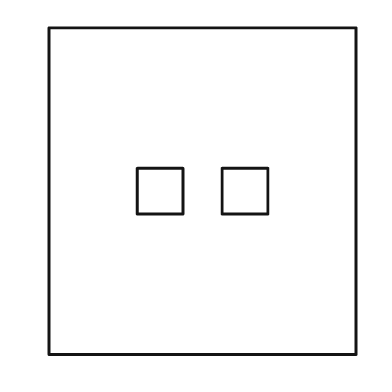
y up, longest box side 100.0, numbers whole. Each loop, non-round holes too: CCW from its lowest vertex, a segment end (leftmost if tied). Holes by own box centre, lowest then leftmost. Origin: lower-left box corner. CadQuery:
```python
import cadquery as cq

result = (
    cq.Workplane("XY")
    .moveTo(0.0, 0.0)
    .lineTo(94.0, 0.0)
    .lineTo(94.0, 100.0)
    .lineTo(0.0, 100.0)
    .close()
    .moveTo(27.0, 43.0)
    .lineTo(41.0, 43.0)
    .lineTo(41.0, 57.0)
    .lineTo(27.0, 57.0)
    .close()
    .moveTo(53.0, 43.0)
    .lineTo(67.0, 43.0)
    .lineTo(67.0, 57.0)
    .lineTo(53.0, 57.0)
    .close()
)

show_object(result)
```